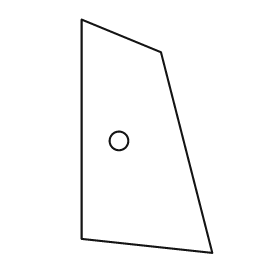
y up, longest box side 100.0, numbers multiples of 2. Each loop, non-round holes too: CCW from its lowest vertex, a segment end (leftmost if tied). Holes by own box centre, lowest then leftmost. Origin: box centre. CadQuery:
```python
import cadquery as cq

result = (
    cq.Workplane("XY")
    .moveTo(28.0, -50.0)
    .lineTo(6.0, 36.0)
    .lineTo(-28.0, 50.0)
    .lineTo(-28.0, -44.0)
    .close()
    .moveTo(-12.0, -2.0)
    .circle(4.0)
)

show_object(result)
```